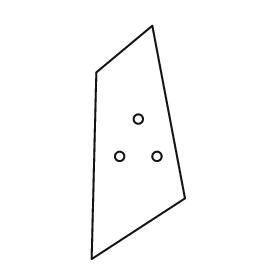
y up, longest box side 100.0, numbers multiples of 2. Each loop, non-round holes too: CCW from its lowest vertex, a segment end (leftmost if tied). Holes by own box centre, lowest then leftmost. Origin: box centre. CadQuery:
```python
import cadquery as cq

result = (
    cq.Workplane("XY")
    .moveTo(-20.0, -50.0)
    .lineTo(20.0, -24.0)
    .lineTo(6.0, 50.0)
    .lineTo(-18.0, 30.0)
    .close()
    .moveTo(-8.0, -6.0)
    .circle(2.0)
    .moveTo(8.0, -6.0)
    .circle(2.0)
    .moveTo(0.0, 10.0)
    .circle(2.0)
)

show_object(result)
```